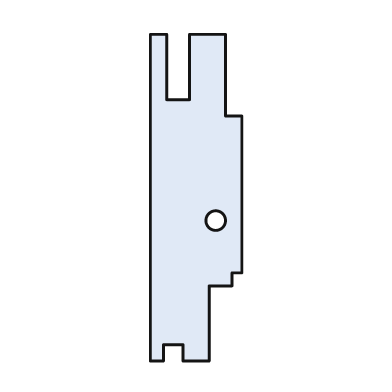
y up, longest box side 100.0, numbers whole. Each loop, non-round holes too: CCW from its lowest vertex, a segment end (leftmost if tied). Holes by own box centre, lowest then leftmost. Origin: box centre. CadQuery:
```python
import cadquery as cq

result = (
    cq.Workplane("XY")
    .moveTo(-14.0, -50.0)
    .lineTo(-10.0, -50.0)
    .lineTo(-10.0, -45.0)
    .lineTo(-4.0, -45.0)
    .lineTo(-4.0, -50.0)
    .lineTo(4.0, -50.0)
    .lineTo(4.0, -27.0)
    .lineTo(11.0, -27.0)
    .lineTo(11.0, -23.0)
    .lineTo(14.0, -23.0)
    .lineTo(14.0, 25.0)
    .lineTo(9.0, 25.0)
    .lineTo(9.0, 50.0)
    .lineTo(-2.0, 50.0)
    .lineTo(-2.0, 30.0)
    .lineTo(-9.0, 30.0)
    .lineTo(-9.0, 50.0)
    .lineTo(-14.0, 50.0)
    .close()
    .moveTo(6.0, -7.0)
    .circle(3.0)
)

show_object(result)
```